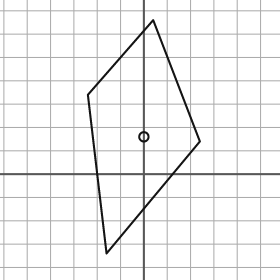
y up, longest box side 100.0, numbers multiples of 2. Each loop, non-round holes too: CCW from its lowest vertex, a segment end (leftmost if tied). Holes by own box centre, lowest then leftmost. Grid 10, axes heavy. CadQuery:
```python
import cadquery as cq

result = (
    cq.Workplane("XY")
    .moveTo(-16.0, -34.0)
    .lineTo(24.0, 14.0)
    .lineTo(4.0, 66.0)
    .lineTo(-24.0, 34.0)
    .close()
    .moveTo(0.0, 16.0)
    .circle(2.0)
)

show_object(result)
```